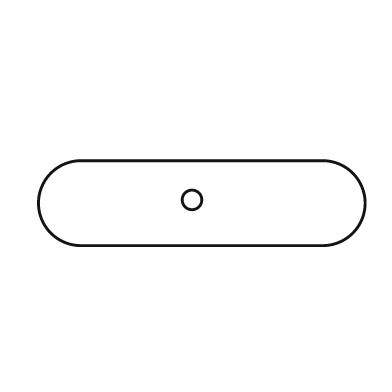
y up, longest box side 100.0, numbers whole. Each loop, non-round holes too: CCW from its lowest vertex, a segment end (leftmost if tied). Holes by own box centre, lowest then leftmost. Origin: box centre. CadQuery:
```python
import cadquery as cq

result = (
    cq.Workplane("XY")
    .moveTo(-37.0, -13.0)
    .lineTo(37.0, -13.0)
    .threePointArc((50.0, 0.0), (37.0, 13.0))
    .lineTo(-37.0, 13.0)
    .threePointArc((-50.0, 0.0), (-37.0, -13.0))
    .close()
    .moveTo(-3.0, 1.0)
    .circle(3.0)
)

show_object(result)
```